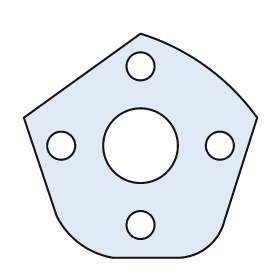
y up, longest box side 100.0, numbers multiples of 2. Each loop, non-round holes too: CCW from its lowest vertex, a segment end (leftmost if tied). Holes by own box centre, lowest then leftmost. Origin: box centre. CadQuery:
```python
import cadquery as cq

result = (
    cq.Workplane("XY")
    .moveTo(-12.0, -48.0)
    .lineTo(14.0, -48.0)
    .threePointArc((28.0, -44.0), (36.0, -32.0))
    .lineTo(50.0, 12.0)
    .threePointArc((28.0, 34.0), (0.0, 48.0))
    .lineTo(-50.0, 12.0)
    .lineTo(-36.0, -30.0)
    .threePointArc((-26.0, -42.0), (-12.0, -48.0))
    .close()
    .moveTo(0.0, -34.0)
    .circle(6.0)
    .moveTo(-34.0, 0.0)
    .circle(6.0)
    .moveTo(0.0, 0.0)
    .circle(16.0)
    .moveTo(34.0, 0.0)
    .circle(6.0)
    .moveTo(0.0, 34.0)
    .circle(6.0)
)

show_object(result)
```